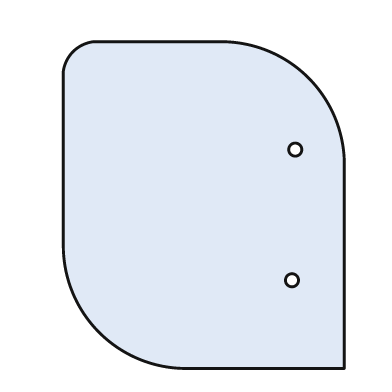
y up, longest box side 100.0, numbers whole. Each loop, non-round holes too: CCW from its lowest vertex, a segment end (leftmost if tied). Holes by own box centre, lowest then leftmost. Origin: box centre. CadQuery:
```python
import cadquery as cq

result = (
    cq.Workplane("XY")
    .moveTo(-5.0, -50.0)
    .lineTo(43.0, -50.0)
    .lineTo(43.0, 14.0)
    .threePointArc((32.0, 39.0), (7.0, 50.0))
    .lineTo(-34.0, 50.0)
    .threePointArc((-40.0, 47.0), (-43.0, 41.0))
    .lineTo(-43.0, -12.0)
    .threePointArc((-32.0, -39.0), (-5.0, -50.0))
    .close()
    .moveTo(27.0, -23.0)
    .circle(2.0)
    .moveTo(28.0, 17.0)
    .circle(2.0)
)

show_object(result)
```